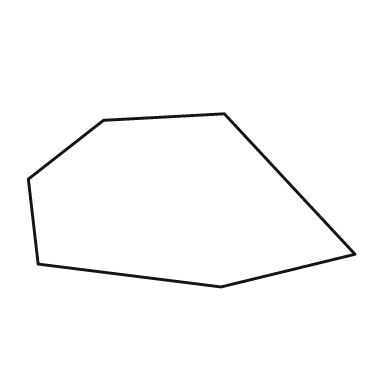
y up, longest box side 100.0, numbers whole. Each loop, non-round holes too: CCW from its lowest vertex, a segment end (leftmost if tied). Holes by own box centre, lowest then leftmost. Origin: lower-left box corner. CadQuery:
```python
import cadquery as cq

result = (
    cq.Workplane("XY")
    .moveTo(59.0, 0.0)
    .lineTo(100.0, 10.0)
    .lineTo(60.0, 53.0)
    .lineTo(23.0, 51.0)
    .lineTo(0.0, 33.0)
    .lineTo(3.0, 7.0)
    .close()
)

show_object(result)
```